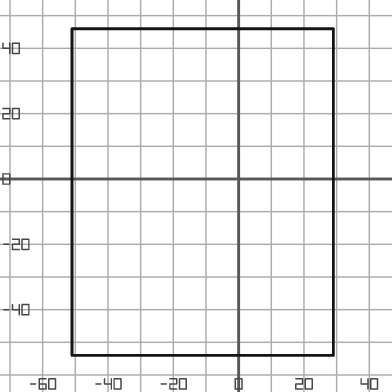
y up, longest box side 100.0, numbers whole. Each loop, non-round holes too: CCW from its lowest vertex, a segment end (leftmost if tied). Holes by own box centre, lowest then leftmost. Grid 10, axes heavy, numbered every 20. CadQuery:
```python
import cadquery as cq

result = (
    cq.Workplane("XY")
    .moveTo(-51.0, -54.0)
    .lineTo(29.0, -54.0)
    .lineTo(29.0, 46.0)
    .lineTo(-51.0, 46.0)
    .close()
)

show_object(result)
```